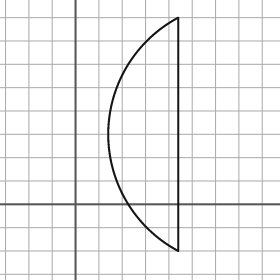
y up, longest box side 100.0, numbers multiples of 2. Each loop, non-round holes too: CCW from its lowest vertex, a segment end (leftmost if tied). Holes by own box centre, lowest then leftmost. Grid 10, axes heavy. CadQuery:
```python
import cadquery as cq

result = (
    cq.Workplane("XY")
    .moveTo(44.0, -20.0)
    .lineTo(44.0, 80.0)
    .threePointArc((14.0, 30.0), (44.0, -20.0))
    .close()
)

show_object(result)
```